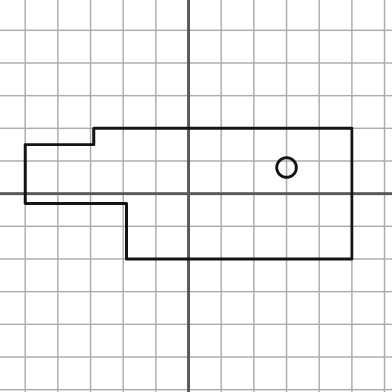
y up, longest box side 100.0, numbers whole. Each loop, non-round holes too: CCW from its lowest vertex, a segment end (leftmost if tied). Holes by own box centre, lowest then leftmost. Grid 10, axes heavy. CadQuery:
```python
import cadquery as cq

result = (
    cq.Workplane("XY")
    .moveTo(-19.0, -20.0)
    .lineTo(50.0, -20.0)
    .lineTo(50.0, 20.0)
    .lineTo(-29.0, 20.0)
    .lineTo(-29.0, 15.0)
    .lineTo(-50.0, 15.0)
    .lineTo(-50.0, -3.0)
    .lineTo(-19.0, -3.0)
    .close()
    .moveTo(30.0, 8.0)
    .circle(3.0)
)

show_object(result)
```